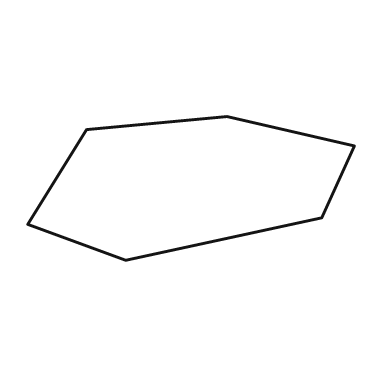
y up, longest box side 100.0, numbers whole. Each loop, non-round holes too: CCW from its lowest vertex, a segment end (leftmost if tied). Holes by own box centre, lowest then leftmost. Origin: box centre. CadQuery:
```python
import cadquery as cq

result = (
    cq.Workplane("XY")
    .moveTo(-20.0, -22.0)
    .lineTo(40.0, -9.0)
    .lineTo(50.0, 13.0)
    .lineTo(11.0, 22.0)
    .lineTo(-32.0, 18.0)
    .lineTo(-50.0, -11.0)
    .close()
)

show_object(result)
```